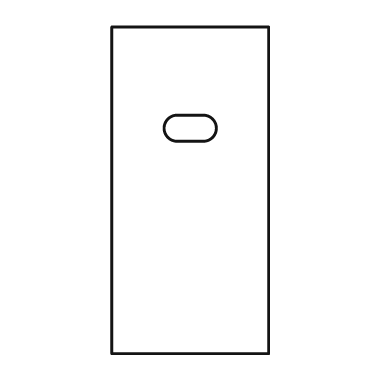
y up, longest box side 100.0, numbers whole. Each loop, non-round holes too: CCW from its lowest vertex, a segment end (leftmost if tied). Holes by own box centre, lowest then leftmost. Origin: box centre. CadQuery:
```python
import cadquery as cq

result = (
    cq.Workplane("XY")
    .moveTo(-24.0, -50.0)
    .lineTo(24.0, -50.0)
    .lineTo(24.0, 50.0)
    .lineTo(-24.0, 50.0)
    .close()
    .moveTo(-4.0, 15.0)
    .lineTo(4.0, 15.0)
    .threePointArc((8.0, 19.0), (4.0, 23.0))
    .lineTo(-4.0, 23.0)
    .threePointArc((-8.0, 19.0), (-4.0, 15.0))
    .close()
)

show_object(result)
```